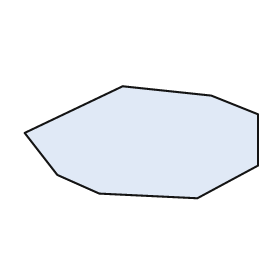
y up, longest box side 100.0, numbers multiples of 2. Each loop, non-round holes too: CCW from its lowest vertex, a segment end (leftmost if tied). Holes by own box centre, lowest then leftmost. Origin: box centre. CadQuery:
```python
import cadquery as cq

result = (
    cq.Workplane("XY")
    .moveTo(24.0, -24.0)
    .lineTo(50.0, -10.0)
    .lineTo(50.0, 12.0)
    .lineTo(30.0, 20.0)
    .lineTo(-8.0, 24.0)
    .lineTo(-50.0, 4.0)
    .lineTo(-36.0, -14.0)
    .lineTo(-18.0, -22.0)
    .close()
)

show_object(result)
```